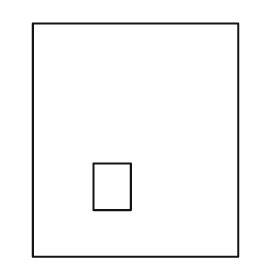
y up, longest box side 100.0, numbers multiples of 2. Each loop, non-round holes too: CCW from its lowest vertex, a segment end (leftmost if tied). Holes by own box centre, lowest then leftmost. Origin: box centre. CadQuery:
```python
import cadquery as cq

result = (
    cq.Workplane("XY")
    .moveTo(-44.0, -50.0)
    .lineTo(44.0, -50.0)
    .lineTo(44.0, 50.0)
    .lineTo(-44.0, 50.0)
    .close()
    .moveTo(-18.0, -30.0)
    .lineTo(-2.0, -30.0)
    .lineTo(-2.0, -10.0)
    .lineTo(-18.0, -10.0)
    .close()
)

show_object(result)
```